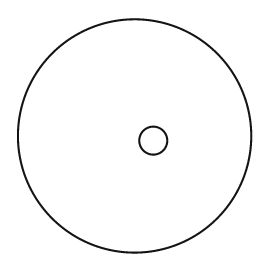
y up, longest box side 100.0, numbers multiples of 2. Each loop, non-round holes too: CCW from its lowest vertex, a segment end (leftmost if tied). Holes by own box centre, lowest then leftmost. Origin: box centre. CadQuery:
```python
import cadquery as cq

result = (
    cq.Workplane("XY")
    .moveTo(0.0, 0.0)
    .circle(50.0)
    .moveTo(8.0, -2.0)
    .circle(6.0)
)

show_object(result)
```